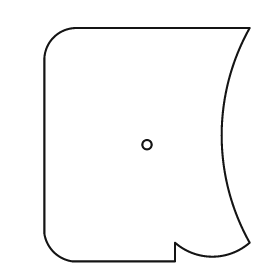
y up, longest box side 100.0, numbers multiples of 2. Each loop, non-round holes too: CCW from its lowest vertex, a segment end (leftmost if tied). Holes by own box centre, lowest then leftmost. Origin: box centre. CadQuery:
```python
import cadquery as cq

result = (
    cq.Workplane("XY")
    .moveTo(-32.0, -50.0)
    .lineTo(12.0, -50.0)
    .lineTo(12.0, -42.0)
    .threePointArc((28.0, -48.0), (44.0, -42.0))
    .threePointArc((32.0, 4.0), (44.0, 50.0))
    .lineTo(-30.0, 50.0)
    .threePointArc((-40.0, 46.0), (-44.0, 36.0))
    .lineTo(-44.0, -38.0)
    .threePointArc((-40.0, -46.0), (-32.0, -50.0))
    .close()
    .moveTo(0.0, 0.0)
    .circle(2.0)
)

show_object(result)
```